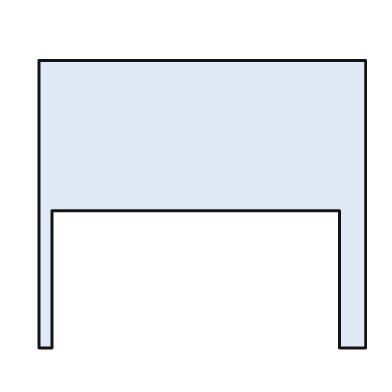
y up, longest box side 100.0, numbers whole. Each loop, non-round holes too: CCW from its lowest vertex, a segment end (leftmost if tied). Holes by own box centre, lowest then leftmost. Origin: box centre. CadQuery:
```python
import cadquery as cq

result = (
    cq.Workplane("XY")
    .moveTo(-50.0, -44.0)
    .lineTo(-46.0, -44.0)
    .lineTo(-46.0, -2.0)
    .lineTo(42.0, -2.0)
    .lineTo(42.0, -44.0)
    .lineTo(50.0, -44.0)
    .lineTo(50.0, 44.0)
    .lineTo(-50.0, 44.0)
    .close()
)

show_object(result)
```